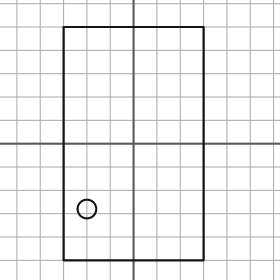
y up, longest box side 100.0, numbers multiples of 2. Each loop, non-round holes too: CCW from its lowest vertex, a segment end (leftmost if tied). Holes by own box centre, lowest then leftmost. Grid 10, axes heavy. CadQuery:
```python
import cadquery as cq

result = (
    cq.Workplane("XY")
    .moveTo(-30.0, -50.0)
    .lineTo(30.0, -50.0)
    .lineTo(30.0, 50.0)
    .lineTo(-30.0, 50.0)
    .close()
    .moveTo(-20.0, -28.0)
    .circle(4.0)
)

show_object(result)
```